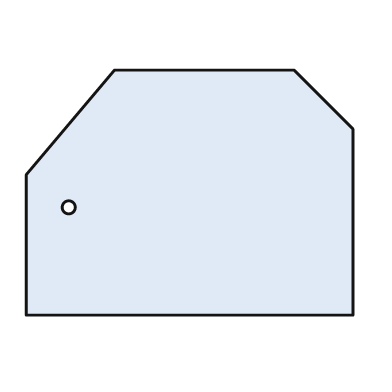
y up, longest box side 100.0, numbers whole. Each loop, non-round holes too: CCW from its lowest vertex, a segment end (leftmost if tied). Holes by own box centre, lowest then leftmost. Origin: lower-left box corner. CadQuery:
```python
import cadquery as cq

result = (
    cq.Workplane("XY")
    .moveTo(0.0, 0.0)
    .lineTo(100.0, 0.0)
    .lineTo(100.0, 57.0)
    .lineTo(82.0, 75.0)
    .lineTo(27.0, 75.0)
    .lineTo(0.0, 43.0)
    .close()
    .moveTo(13.0, 33.0)
    .circle(2.0)
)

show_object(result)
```